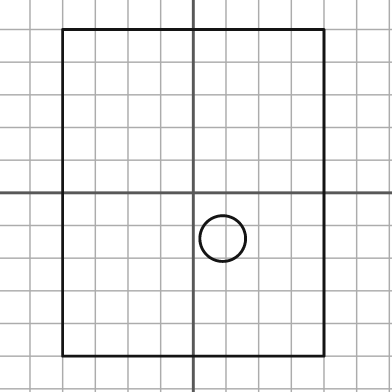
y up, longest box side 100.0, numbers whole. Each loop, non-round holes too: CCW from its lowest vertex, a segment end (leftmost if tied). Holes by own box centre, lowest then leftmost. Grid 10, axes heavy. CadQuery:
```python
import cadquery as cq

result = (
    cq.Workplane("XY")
    .moveTo(-40.0, -50.0)
    .lineTo(40.0, -50.0)
    .lineTo(40.0, 50.0)
    .lineTo(-40.0, 50.0)
    .close()
    .moveTo(9.0, -14.0)
    .circle(7.0)
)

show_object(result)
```